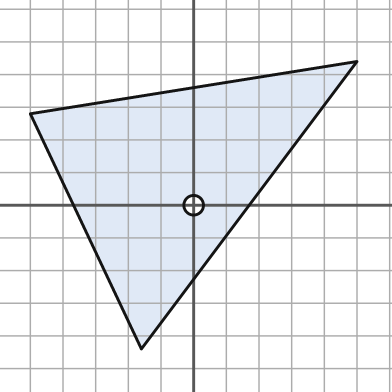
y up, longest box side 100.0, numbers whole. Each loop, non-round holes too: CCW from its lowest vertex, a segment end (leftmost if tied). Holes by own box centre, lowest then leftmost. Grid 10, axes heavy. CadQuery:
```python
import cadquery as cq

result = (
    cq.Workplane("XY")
    .moveTo(-16.0, -44.0)
    .lineTo(50.0, 44.0)
    .lineTo(-50.0, 28.0)
    .close()
    .moveTo(0.0, 0.0)
    .circle(3.0)
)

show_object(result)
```